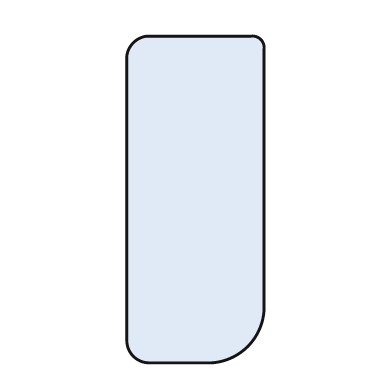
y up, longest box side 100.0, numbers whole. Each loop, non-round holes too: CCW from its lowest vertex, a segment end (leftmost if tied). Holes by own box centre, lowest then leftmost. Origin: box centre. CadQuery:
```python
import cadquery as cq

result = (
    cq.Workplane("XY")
    .moveTo(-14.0, -50.0)
    .lineTo(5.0, -50.0)
    .threePointArc((16.0, -45.0), (21.0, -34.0))
    .lineTo(21.0, 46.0)
    .threePointArc((20.0, 49.0), (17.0, 50.0))
    .lineTo(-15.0, 50.0)
    .threePointArc((-19.0, 48.0), (-21.0, 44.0))
    .lineTo(-21.0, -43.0)
    .threePointArc((-19.0, -48.0), (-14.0, -50.0))
    .close()
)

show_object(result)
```